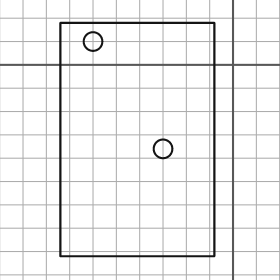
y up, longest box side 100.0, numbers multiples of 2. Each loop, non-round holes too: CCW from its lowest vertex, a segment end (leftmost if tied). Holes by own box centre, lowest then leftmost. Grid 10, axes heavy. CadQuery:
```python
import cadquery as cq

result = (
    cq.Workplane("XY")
    .moveTo(-74.0, -82.0)
    .lineTo(-8.0, -82.0)
    .lineTo(-8.0, 18.0)
    .lineTo(-74.0, 18.0)
    .close()
    .moveTo(-30.0, -36.0)
    .circle(4.0)
    .moveTo(-60.0, 10.0)
    .circle(4.0)
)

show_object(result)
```